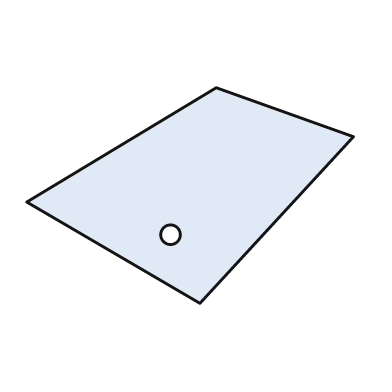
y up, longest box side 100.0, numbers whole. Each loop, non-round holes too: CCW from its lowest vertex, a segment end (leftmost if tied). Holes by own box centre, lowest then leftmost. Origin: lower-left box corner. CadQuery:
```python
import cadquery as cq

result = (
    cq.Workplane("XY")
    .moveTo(53.0, 0.0)
    .lineTo(100.0, 51.0)
    .lineTo(58.0, 66.0)
    .lineTo(0.0, 31.0)
    .close()
    .moveTo(44.0, 21.0)
    .circle(3.0)
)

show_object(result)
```